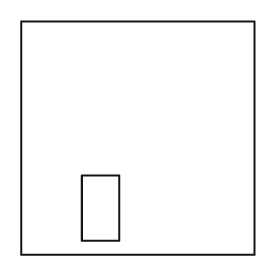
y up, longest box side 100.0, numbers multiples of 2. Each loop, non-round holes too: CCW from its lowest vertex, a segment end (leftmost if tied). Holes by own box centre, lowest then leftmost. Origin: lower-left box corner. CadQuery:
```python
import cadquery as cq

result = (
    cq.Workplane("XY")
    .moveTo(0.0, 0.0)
    .lineTo(100.0, 0.0)
    .lineTo(100.0, 100.0)
    .lineTo(0.0, 100.0)
    .close()
    .moveTo(26.0, 6.0)
    .lineTo(42.0, 6.0)
    .lineTo(42.0, 34.0)
    .lineTo(26.0, 34.0)
    .close()
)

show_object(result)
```